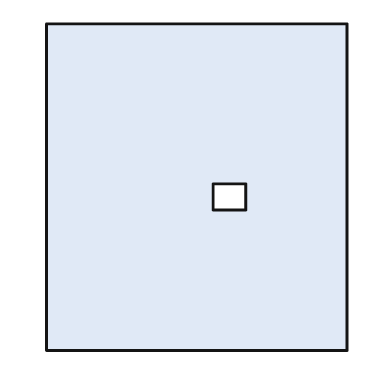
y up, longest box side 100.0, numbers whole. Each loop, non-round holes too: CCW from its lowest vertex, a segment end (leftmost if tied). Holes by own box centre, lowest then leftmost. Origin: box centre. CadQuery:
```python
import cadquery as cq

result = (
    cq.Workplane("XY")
    .moveTo(-46.0, -50.0)
    .lineTo(46.0, -50.0)
    .lineTo(46.0, 50.0)
    .lineTo(-46.0, 50.0)
    .close()
    .moveTo(5.0, -7.0)
    .lineTo(15.0, -7.0)
    .lineTo(15.0, 1.0)
    .lineTo(5.0, 1.0)
    .close()
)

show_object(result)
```